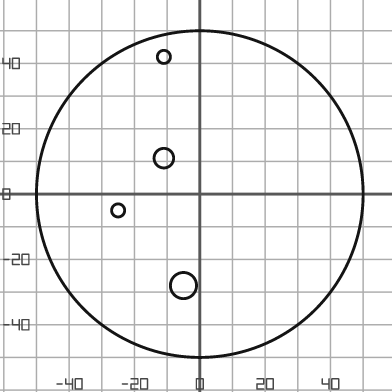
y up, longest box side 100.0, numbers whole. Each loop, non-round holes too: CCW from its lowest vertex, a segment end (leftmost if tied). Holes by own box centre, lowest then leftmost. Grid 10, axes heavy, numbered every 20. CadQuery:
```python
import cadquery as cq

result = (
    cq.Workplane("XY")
    .moveTo(0.0, 0.0)
    .circle(50.0)
    .moveTo(-5.0, -28.0)
    .circle(4.0)
    .moveTo(-25.0, -5.0)
    .circle(2.0)
    .moveTo(-11.0, 11.0)
    .circle(3.0)
    .moveTo(-11.0, 42.0)
    .circle(2.0)
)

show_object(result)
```